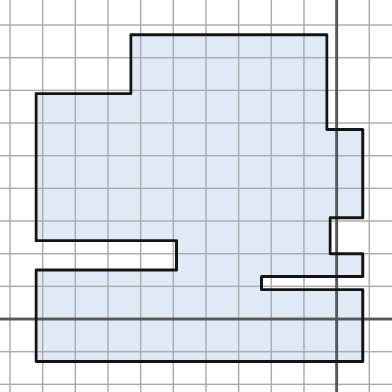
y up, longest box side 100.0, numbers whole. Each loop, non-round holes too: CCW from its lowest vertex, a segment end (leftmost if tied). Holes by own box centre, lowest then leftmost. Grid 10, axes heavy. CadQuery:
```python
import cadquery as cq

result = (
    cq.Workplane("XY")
    .moveTo(-92.0, -13.0)
    .lineTo(8.0, -13.0)
    .lineTo(8.0, 9.0)
    .lineTo(-23.0, 9.0)
    .lineTo(-23.0, 13.0)
    .lineTo(8.0, 13.0)
    .lineTo(8.0, 20.0)
    .lineTo(-2.0, 20.0)
    .lineTo(-2.0, 31.0)
    .lineTo(8.0, 31.0)
    .lineTo(8.0, 58.0)
    .lineTo(-3.0, 58.0)
    .lineTo(-3.0, 87.0)
    .lineTo(-63.0, 87.0)
    .lineTo(-63.0, 69.0)
    .lineTo(-92.0, 69.0)
    .lineTo(-92.0, 24.0)
    .lineTo(-49.0, 24.0)
    .lineTo(-49.0, 15.0)
    .lineTo(-92.0, 15.0)
    .close()
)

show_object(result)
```